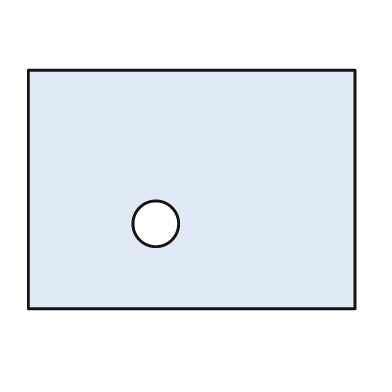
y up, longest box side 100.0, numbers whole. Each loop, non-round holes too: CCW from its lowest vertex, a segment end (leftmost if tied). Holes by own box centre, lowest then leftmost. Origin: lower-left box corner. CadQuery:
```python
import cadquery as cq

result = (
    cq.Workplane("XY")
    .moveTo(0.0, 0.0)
    .lineTo(100.0, 0.0)
    .lineTo(100.0, 73.0)
    .lineTo(0.0, 73.0)
    .close()
    .moveTo(39.0, 26.0)
    .circle(7.0)
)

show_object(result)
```